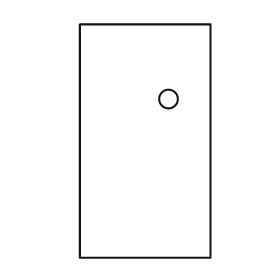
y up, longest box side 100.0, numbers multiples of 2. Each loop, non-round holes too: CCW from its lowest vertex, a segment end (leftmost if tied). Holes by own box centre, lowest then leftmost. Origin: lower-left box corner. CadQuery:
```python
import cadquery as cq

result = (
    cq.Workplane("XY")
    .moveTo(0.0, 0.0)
    .lineTo(56.0, 0.0)
    .lineTo(56.0, 100.0)
    .lineTo(0.0, 100.0)
    .close()
    .moveTo(38.0, 68.0)
    .circle(4.0)
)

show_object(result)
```